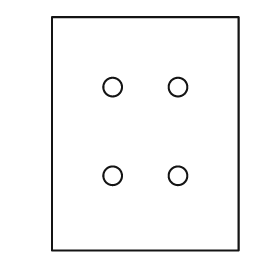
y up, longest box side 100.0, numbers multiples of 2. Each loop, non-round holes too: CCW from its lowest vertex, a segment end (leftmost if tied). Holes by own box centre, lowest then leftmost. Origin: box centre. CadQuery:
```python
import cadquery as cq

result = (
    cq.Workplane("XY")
    .moveTo(-40.0, -50.0)
    .lineTo(40.0, -50.0)
    .lineTo(40.0, 50.0)
    .lineTo(-40.0, 50.0)
    .close()
    .moveTo(-14.0, -18.0)
    .circle(4.0)
    .moveTo(14.0, -18.0)
    .circle(4.0)
    .moveTo(-14.0, 20.0)
    .circle(4.0)
    .moveTo(14.0, 20.0)
    .circle(4.0)
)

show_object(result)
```